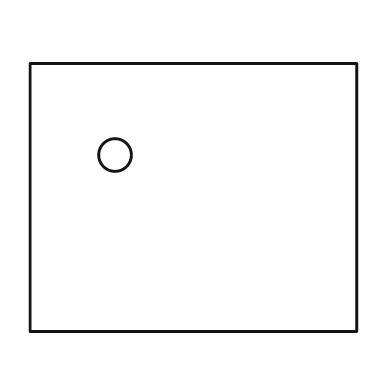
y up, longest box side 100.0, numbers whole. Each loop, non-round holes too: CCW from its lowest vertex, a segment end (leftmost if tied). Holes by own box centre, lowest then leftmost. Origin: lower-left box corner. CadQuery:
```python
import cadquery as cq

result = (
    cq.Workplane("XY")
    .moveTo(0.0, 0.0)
    .lineTo(100.0, 0.0)
    .lineTo(100.0, 82.0)
    .lineTo(0.0, 82.0)
    .close()
    .moveTo(26.0, 54.0)
    .circle(5.0)
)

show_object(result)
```